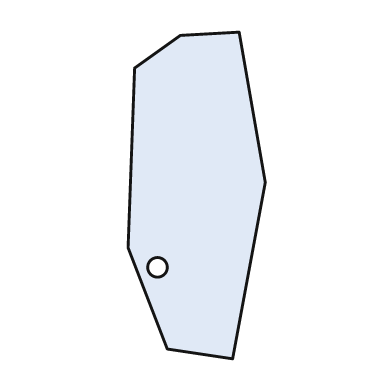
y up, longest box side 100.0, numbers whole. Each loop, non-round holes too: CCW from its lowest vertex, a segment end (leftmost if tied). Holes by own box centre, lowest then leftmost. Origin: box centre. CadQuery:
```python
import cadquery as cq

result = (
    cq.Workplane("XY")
    .moveTo(11.0, -50.0)
    .lineTo(21.0, 4.0)
    .lineTo(13.0, 50.0)
    .lineTo(-5.0, 49.0)
    .lineTo(-19.0, 39.0)
    .lineTo(-21.0, -16.0)
    .lineTo(-9.0, -47.0)
    .close()
    .moveTo(-12.0, -22.0)
    .circle(3.0)
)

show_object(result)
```